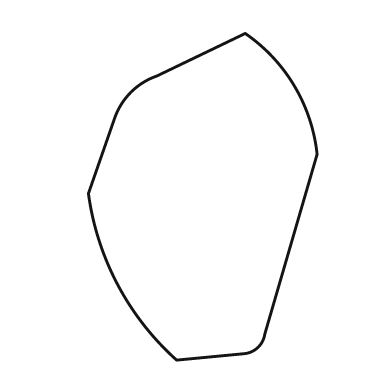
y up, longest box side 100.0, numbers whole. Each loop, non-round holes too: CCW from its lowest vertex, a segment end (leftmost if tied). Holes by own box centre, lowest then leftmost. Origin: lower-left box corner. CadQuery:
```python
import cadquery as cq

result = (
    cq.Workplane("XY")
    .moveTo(27.0, 0.0)
    .lineTo(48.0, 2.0)
    .threePointArc((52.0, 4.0), (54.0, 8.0))
    .lineTo(70.0, 63.0)
    .threePointArc((63.0, 84.0), (48.0, 100.0))
    .lineTo(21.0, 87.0)
    .threePointArc((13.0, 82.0), (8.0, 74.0))
    .lineTo(0.0, 51.0)
    .threePointArc((9.0, 23.0), (27.0, 0.0))
    .close()
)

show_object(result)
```